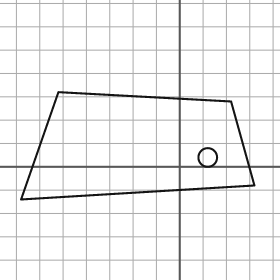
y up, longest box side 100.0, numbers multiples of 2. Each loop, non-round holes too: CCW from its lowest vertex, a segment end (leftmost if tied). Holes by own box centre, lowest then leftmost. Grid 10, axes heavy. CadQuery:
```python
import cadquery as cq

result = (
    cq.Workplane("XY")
    .moveTo(-68.0, -14.0)
    .lineTo(32.0, -8.0)
    .lineTo(22.0, 28.0)
    .lineTo(-52.0, 32.0)
    .close()
    .moveTo(12.0, 4.0)
    .circle(4.0)
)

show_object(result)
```